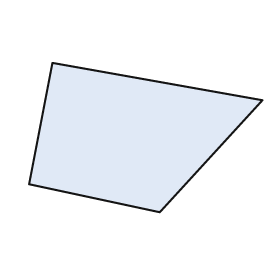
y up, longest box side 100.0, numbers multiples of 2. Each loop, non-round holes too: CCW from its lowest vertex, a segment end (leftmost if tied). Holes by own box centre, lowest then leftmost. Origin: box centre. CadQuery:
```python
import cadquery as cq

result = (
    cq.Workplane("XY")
    .moveTo(6.0, -32.0)
    .lineTo(50.0, 16.0)
    .lineTo(-40.0, 32.0)
    .lineTo(-50.0, -20.0)
    .close()
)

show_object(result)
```